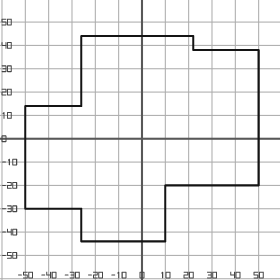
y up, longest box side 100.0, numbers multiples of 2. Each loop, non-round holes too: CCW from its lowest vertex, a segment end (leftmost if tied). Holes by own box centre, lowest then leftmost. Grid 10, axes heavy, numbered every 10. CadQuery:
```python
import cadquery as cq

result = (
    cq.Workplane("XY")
    .moveTo(-26.0, -44.0)
    .lineTo(10.0, -44.0)
    .lineTo(10.0, -20.0)
    .lineTo(50.0, -20.0)
    .lineTo(50.0, 38.0)
    .lineTo(22.0, 38.0)
    .lineTo(22.0, 44.0)
    .lineTo(-26.0, 44.0)
    .lineTo(-26.0, 14.0)
    .lineTo(-50.0, 14.0)
    .lineTo(-50.0, -30.0)
    .lineTo(-26.0, -30.0)
    .close()
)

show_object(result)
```